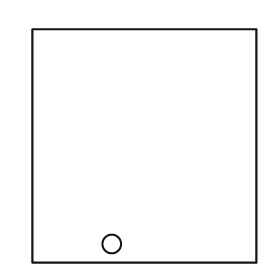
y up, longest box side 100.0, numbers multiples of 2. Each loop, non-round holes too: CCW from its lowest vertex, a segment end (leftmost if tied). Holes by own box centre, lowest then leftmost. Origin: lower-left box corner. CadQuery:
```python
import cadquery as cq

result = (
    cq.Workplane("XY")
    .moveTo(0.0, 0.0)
    .lineTo(96.0, 0.0)
    .lineTo(96.0, 100.0)
    .lineTo(0.0, 100.0)
    .close()
    .moveTo(34.0, 8.0)
    .circle(4.0)
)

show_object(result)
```